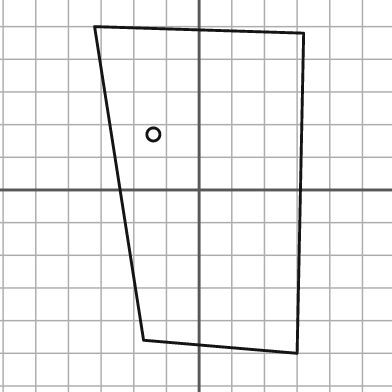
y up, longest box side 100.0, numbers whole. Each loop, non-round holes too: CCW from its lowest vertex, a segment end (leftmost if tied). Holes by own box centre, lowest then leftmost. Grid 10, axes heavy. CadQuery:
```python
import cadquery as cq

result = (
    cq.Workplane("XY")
    .moveTo(30.0, -50.0)
    .lineTo(32.0, 48.0)
    .lineTo(-32.0, 50.0)
    .lineTo(-17.0, -46.0)
    .close()
    .moveTo(-14.0, 17.0)
    .circle(2.0)
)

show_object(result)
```